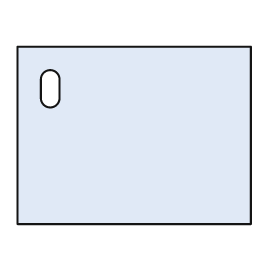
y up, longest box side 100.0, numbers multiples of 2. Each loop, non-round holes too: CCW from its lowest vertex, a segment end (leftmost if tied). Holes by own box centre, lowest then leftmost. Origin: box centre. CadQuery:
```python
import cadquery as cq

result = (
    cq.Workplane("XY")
    .moveTo(-50.0, -38.0)
    .lineTo(50.0, -38.0)
    .lineTo(50.0, 38.0)
    .lineTo(-50.0, 38.0)
    .close()
    .moveTo(-40.0, 16.0)
    .threePointArc((-36.0, 12.0), (-32.0, 16.0))
    .lineTo(-32.0, 24.0)
    .threePointArc((-36.0, 28.0), (-40.0, 24.0))
    .close()
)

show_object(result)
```